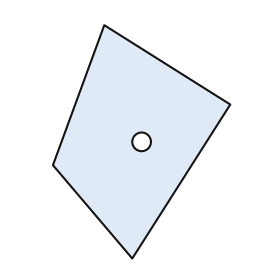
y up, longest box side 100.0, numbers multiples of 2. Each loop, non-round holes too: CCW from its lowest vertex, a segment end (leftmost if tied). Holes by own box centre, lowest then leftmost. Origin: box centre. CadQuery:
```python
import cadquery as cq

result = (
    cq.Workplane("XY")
    .moveTo(-4.0, -50.0)
    .lineTo(38.0, 16.0)
    .lineTo(-16.0, 50.0)
    .lineTo(-38.0, -10.0)
    .close()
    .moveTo(0.0, 0.0)
    .circle(4.0)
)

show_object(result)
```